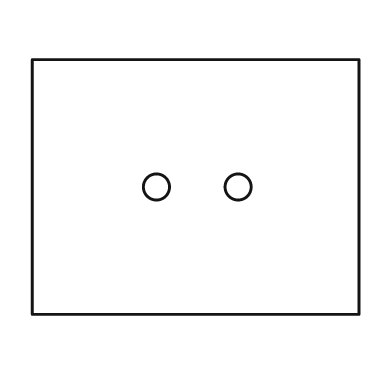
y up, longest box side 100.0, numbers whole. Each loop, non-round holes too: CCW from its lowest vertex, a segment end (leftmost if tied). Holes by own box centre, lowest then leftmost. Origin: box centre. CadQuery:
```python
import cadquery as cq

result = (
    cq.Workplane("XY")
    .moveTo(-50.0, -39.0)
    .lineTo(50.0, -39.0)
    .lineTo(50.0, 39.0)
    .lineTo(-50.0, 39.0)
    .close()
    .moveTo(-12.0, 0.0)
    .circle(4.0)
    .moveTo(13.0, 0.0)
    .circle(4.0)
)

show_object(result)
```